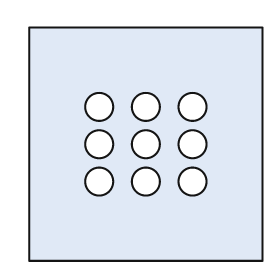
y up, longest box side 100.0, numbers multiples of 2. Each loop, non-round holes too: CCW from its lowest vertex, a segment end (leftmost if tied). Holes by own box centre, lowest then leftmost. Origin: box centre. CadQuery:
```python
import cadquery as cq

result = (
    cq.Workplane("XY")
    .moveTo(-50.0, -50.0)
    .lineTo(50.0, -50.0)
    .lineTo(50.0, 50.0)
    .lineTo(-50.0, 50.0)
    .close()
    .moveTo(-20.0, -16.0)
    .circle(6.0)
    .moveTo(0.0, -16.0)
    .circle(6.0)
    .moveTo(20.0, -16.0)
    .circle(6.0)
    .moveTo(-20.0, 0.0)
    .circle(6.0)
    .moveTo(0.0, 0.0)
    .circle(6.0)
    .moveTo(20.0, 0.0)
    .circle(6.0)
    .moveTo(-20.0, 16.0)
    .circle(6.0)
    .moveTo(0.0, 16.0)
    .circle(6.0)
    .moveTo(20.0, 16.0)
    .circle(6.0)
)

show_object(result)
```